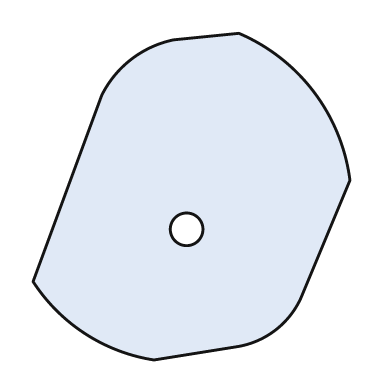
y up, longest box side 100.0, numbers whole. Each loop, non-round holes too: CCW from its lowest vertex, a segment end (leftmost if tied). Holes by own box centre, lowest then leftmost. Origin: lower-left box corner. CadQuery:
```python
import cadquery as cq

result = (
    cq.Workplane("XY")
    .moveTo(37.0, 0.0)
    .lineTo(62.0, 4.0)
    .threePointArc((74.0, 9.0), (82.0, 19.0))
    .lineTo(97.0, 55.0)
    .threePointArc((86.0, 82.0), (63.0, 100.0))
    .lineTo(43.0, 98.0)
    .threePointArc((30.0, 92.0), (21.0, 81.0))
    .lineTo(0.0, 24.0)
    .threePointArc((16.0, 8.0), (37.0, 0.0))
    .close()
    .moveTo(47.0, 40.0)
    .circle(5.0)
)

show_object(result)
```